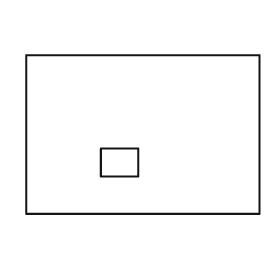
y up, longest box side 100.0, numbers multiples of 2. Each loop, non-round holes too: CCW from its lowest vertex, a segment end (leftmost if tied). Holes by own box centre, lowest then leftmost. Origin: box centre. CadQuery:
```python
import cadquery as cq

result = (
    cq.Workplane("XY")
    .moveTo(-50.0, -34.0)
    .lineTo(50.0, -34.0)
    .lineTo(50.0, 34.0)
    .lineTo(-50.0, 34.0)
    .close()
    .moveTo(-18.0, -18.0)
    .lineTo(-2.0, -18.0)
    .lineTo(-2.0, -6.0)
    .lineTo(-18.0, -6.0)
    .close()
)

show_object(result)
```